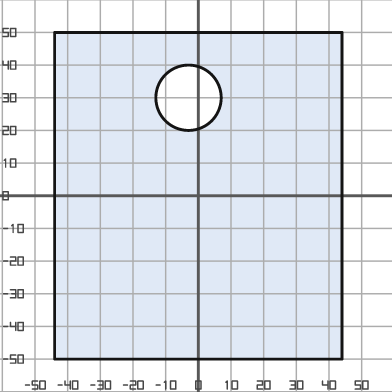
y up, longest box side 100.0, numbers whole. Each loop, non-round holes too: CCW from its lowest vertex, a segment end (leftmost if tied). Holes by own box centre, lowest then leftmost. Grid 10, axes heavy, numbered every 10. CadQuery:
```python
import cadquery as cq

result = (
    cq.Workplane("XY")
    .moveTo(-44.0, -50.0)
    .lineTo(44.0, -50.0)
    .lineTo(44.0, 50.0)
    .lineTo(-44.0, 50.0)
    .close()
    .moveTo(-3.0, 30.0)
    .circle(10.0)
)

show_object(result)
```